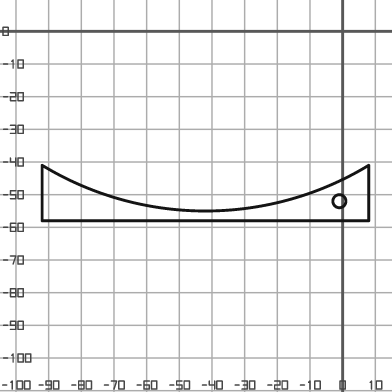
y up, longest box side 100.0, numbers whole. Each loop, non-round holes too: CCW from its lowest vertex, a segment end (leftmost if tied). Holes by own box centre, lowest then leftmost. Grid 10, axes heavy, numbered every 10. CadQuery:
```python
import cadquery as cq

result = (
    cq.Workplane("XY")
    .moveTo(-92.0, -58.0)
    .lineTo(8.0, -58.0)
    .lineTo(8.0, -41.0)
    .threePointArc((-42.0, -55.0), (-92.0, -41.0))
    .close()
    .moveTo(-1.0, -52.0)
    .circle(2.0)
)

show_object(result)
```